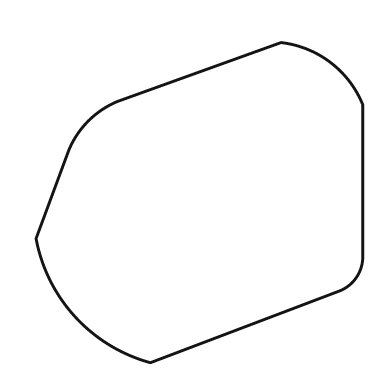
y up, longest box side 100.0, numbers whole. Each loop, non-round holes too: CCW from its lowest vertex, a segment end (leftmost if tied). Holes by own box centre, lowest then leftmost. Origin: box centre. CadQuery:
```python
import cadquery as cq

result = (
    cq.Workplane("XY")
    .moveTo(-15.0, -49.0)
    .lineTo(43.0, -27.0)
    .threePointArc((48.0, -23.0), (50.0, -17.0))
    .lineTo(50.0, 30.0)
    .threePointArc((40.0, 43.0), (25.0, 49.0))
    .lineTo(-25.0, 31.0)
    .threePointArc((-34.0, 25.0), (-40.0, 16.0))
    .lineTo(-50.0, -11.0)
    .threePointArc((-38.0, -35.0), (-15.0, -49.0))
    .close()
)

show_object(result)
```